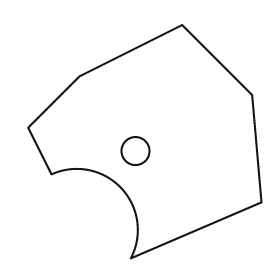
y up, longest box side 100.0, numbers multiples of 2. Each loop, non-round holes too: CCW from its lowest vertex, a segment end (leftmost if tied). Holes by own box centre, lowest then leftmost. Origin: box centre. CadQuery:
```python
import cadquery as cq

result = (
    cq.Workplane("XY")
    .moveTo(-6.0, -50.0)
    .lineTo(50.0, -26.0)
    .lineTo(46.0, 20.0)
    .lineTo(16.0, 50.0)
    .lineTo(-28.0, 28.0)
    .lineTo(-50.0, 6.0)
    .lineTo(-40.0, -14.0)
    .threePointArc((-10.0, -20.0), (-6.0, -50.0))
    .close()
    .moveTo(-4.0, -4.0)
    .circle(6.0)
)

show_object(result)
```